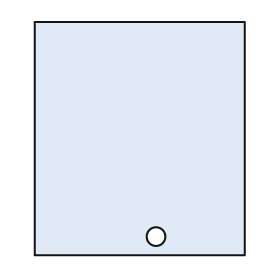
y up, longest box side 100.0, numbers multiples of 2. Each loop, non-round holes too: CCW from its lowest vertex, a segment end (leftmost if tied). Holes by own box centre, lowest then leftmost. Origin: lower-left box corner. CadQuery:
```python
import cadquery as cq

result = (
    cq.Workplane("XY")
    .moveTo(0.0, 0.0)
    .lineTo(90.0, 0.0)
    .lineTo(90.0, 100.0)
    .lineTo(0.0, 100.0)
    .close()
    .moveTo(52.0, 8.0)
    .circle(4.0)
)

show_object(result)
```